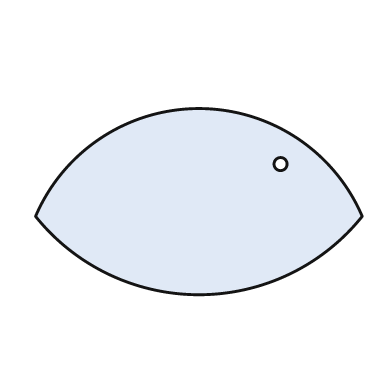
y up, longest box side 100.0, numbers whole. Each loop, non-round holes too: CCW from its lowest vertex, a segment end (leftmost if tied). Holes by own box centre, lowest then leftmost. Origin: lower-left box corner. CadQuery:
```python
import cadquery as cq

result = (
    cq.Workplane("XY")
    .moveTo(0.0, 24.0)
    .threePointArc((50.0, 0.0), (100.0, 24.0))
    .threePointArc((50.0, 57.0), (0.0, 24.0))
    .close()
    .moveTo(75.0, 40.0)
    .circle(2.0)
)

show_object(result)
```